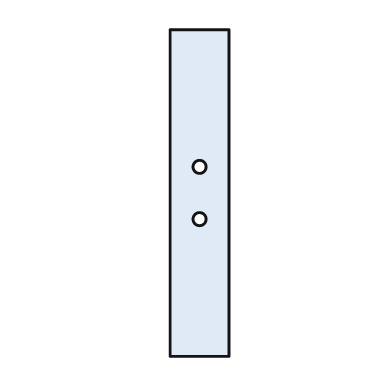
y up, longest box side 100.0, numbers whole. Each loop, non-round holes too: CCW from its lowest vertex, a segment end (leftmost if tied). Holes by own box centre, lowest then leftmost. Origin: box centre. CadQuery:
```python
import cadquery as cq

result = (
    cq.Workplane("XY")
    .moveTo(-9.0, -50.0)
    .lineTo(9.0, -50.0)
    .lineTo(9.0, 50.0)
    .lineTo(-9.0, 50.0)
    .close()
    .moveTo(0.0, -8.0)
    .circle(2.0)
    .moveTo(0.0, 8.0)
    .circle(2.0)
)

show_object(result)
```